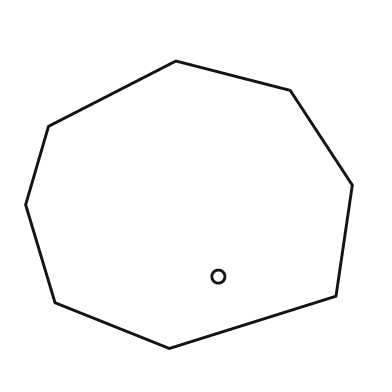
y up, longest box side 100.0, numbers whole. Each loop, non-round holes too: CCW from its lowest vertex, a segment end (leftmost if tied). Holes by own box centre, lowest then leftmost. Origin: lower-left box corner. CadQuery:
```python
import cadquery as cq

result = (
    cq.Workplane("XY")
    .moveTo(44.0, 0.0)
    .lineTo(95.0, 16.0)
    .lineTo(100.0, 50.0)
    .lineTo(81.0, 79.0)
    .lineTo(46.0, 88.0)
    .lineTo(7.0, 68.0)
    .lineTo(0.0, 44.0)
    .lineTo(9.0, 14.0)
    .close()
    .moveTo(59.0, 22.0)
    .circle(2.0)
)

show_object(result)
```